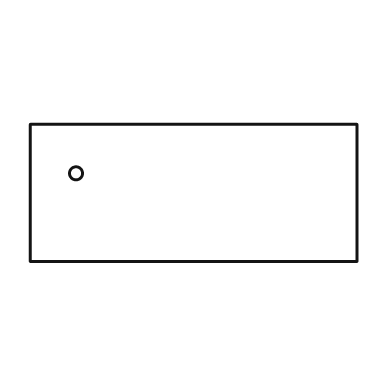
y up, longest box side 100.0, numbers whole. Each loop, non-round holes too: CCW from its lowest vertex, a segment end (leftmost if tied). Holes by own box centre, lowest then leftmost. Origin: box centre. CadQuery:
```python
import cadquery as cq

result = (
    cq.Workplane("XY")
    .moveTo(-50.0, -21.0)
    .lineTo(50.0, -21.0)
    .lineTo(50.0, 21.0)
    .lineTo(-50.0, 21.0)
    .close()
    .moveTo(-36.0, 6.0)
    .circle(2.0)
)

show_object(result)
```